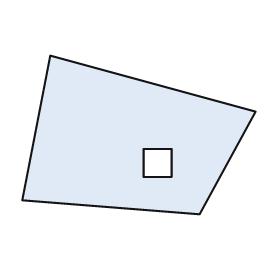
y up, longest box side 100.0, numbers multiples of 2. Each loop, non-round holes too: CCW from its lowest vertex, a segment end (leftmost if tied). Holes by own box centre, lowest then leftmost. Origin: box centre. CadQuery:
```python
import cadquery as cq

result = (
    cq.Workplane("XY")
    .moveTo(26.0, -34.0)
    .lineTo(50.0, 10.0)
    .lineTo(-38.0, 34.0)
    .lineTo(-50.0, -28.0)
    .close()
    .moveTo(2.0, -18.0)
    .lineTo(14.0, -18.0)
    .lineTo(14.0, -6.0)
    .lineTo(2.0, -6.0)
    .close()
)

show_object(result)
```